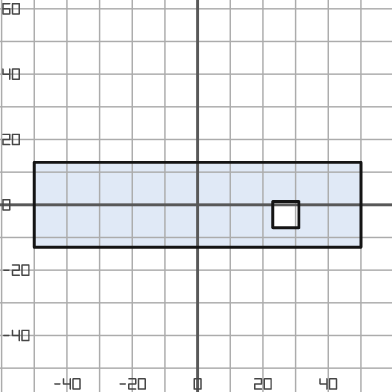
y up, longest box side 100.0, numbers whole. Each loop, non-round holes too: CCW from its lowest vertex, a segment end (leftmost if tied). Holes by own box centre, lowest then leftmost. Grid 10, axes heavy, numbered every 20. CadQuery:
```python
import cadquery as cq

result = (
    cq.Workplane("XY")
    .moveTo(-50.0, -13.0)
    .lineTo(50.0, -13.0)
    .lineTo(50.0, 13.0)
    .lineTo(-50.0, 13.0)
    .close()
    .moveTo(23.0, -7.0)
    .lineTo(31.0, -7.0)
    .lineTo(31.0, 1.0)
    .lineTo(23.0, 1.0)
    .close()
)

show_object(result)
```